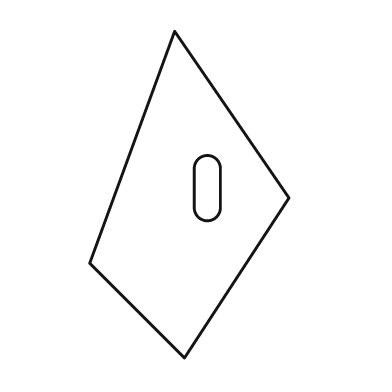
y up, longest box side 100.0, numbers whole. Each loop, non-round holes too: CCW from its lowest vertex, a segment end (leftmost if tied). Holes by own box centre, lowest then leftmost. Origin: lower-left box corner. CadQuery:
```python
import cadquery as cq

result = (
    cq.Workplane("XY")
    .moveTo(29.0, 0.0)
    .lineTo(61.0, 49.0)
    .lineTo(26.0, 100.0)
    .lineTo(0.0, 29.0)
    .close()
    .moveTo(32.0, 46.0)
    .threePointArc((36.0, 42.0), (40.0, 46.0))
    .lineTo(40.0, 58.0)
    .threePointArc((36.0, 62.0), (32.0, 58.0))
    .close()
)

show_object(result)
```